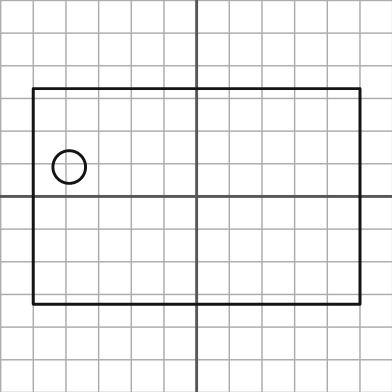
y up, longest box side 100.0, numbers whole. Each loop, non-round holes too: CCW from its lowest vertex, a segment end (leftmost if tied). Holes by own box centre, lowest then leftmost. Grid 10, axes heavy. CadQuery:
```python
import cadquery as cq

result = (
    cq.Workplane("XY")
    .moveTo(-50.0, -33.0)
    .lineTo(50.0, -33.0)
    .lineTo(50.0, 33.0)
    .lineTo(-50.0, 33.0)
    .close()
    .moveTo(-39.0, 9.0)
    .circle(5.0)
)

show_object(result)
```